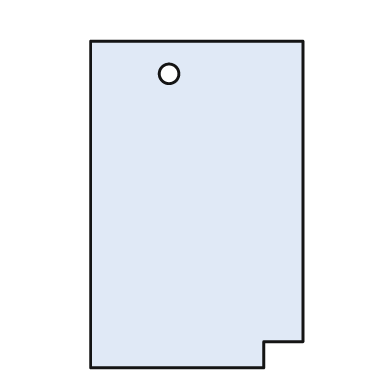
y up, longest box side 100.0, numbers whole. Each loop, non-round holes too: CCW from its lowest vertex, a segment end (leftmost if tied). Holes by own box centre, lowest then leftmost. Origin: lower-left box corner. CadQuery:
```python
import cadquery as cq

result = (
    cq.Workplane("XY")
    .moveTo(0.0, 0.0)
    .lineTo(53.0, 0.0)
    .lineTo(53.0, 8.0)
    .lineTo(65.0, 8.0)
    .lineTo(65.0, 100.0)
    .lineTo(0.0, 100.0)
    .close()
    .moveTo(24.0, 90.0)
    .circle(3.0)
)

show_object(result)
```